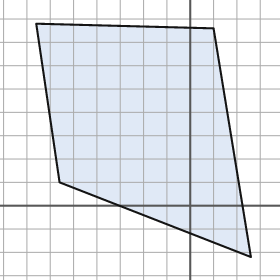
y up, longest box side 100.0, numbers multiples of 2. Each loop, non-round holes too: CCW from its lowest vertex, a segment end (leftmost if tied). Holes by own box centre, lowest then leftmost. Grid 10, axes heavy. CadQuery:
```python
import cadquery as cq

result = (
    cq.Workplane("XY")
    .moveTo(26.0, -22.0)
    .lineTo(10.0, 76.0)
    .lineTo(-66.0, 78.0)
    .lineTo(-56.0, 10.0)
    .close()
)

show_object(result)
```